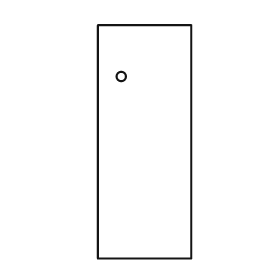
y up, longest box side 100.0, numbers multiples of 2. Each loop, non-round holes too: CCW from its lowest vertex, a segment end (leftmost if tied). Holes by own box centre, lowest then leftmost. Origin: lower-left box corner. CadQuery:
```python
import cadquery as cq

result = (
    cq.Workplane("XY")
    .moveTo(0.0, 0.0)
    .lineTo(40.0, 0.0)
    .lineTo(40.0, 100.0)
    .lineTo(0.0, 100.0)
    .close()
    .moveTo(10.0, 78.0)
    .circle(2.0)
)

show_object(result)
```